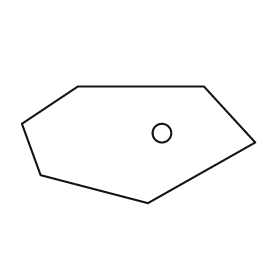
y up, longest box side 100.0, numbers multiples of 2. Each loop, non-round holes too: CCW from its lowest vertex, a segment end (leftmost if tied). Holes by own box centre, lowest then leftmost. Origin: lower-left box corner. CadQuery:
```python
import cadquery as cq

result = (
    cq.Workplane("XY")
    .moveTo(54.0, 0.0)
    .lineTo(100.0, 26.0)
    .lineTo(78.0, 50.0)
    .lineTo(24.0, 50.0)
    .lineTo(0.0, 34.0)
    .lineTo(8.0, 12.0)
    .close()
    .moveTo(60.0, 30.0)
    .circle(4.0)
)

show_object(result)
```